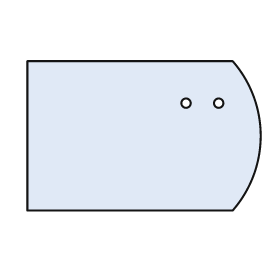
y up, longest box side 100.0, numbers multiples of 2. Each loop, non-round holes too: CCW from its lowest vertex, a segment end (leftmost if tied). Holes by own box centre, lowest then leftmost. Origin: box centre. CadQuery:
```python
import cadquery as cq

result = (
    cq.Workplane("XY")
    .moveTo(-50.0, -32.0)
    .lineTo(38.0, -32.0)
    .threePointArc((50.0, 0.0), (38.0, 32.0))
    .lineTo(-50.0, 32.0)
    .close()
    .moveTo(18.0, 14.0)
    .circle(2.0)
    .moveTo(32.0, 14.0)
    .circle(2.0)
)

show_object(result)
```